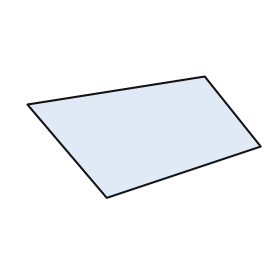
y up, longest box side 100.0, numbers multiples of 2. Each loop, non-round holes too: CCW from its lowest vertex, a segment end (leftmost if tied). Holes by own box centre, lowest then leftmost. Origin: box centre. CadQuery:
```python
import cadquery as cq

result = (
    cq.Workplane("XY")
    .moveTo(-16.0, -26.0)
    .lineTo(50.0, -4.0)
    .lineTo(26.0, 26.0)
    .lineTo(-50.0, 14.0)
    .close()
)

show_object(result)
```